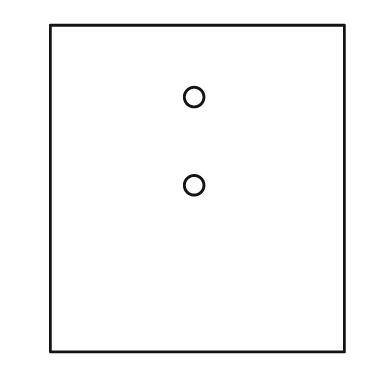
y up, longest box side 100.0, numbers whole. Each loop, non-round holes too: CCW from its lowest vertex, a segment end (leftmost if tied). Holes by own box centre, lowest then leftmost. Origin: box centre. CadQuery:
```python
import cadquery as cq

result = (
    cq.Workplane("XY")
    .moveTo(-45.0, -50.0)
    .lineTo(45.0, -50.0)
    .lineTo(45.0, 50.0)
    .lineTo(-45.0, 50.0)
    .close()
    .moveTo(-1.0, 1.0)
    .circle(3.0)
    .moveTo(-1.0, 28.0)
    .circle(3.0)
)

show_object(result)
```